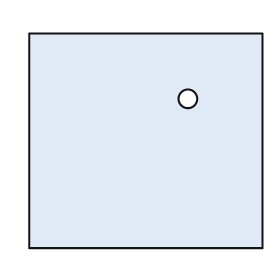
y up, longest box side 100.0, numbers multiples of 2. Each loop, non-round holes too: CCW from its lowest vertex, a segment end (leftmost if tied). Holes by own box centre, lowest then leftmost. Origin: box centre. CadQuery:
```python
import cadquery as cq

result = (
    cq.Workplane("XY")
    .moveTo(-50.0, -46.0)
    .lineTo(50.0, -46.0)
    .lineTo(50.0, 46.0)
    .lineTo(-50.0, 46.0)
    .close()
    .moveTo(18.0, 18.0)
    .circle(4.0)
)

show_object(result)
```